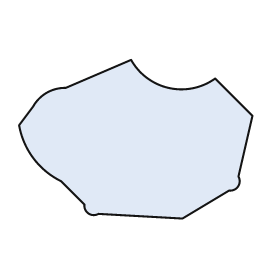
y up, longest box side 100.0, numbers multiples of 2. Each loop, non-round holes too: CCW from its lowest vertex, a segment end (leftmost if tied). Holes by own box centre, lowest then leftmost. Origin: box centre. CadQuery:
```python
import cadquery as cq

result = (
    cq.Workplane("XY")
    .moveTo(20.0, -34.0)
    .lineTo(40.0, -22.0)
    .threePointArc((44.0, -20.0), (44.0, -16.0))
    .lineTo(50.0, 10.0)
    .lineTo(34.0, 26.0)
    .threePointArc((14.0, 22.0), (-2.0, 34.0))
    .lineTo(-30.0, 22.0)
    .threePointArc((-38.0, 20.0), (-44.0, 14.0))
    .lineTo(-50.0, 6.0)
    .threePointArc((-44.0, -8.0), (-32.0, -18.0))
    .lineTo(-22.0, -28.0)
    .threePointArc((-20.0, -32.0), (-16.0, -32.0))
    .close()
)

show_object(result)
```